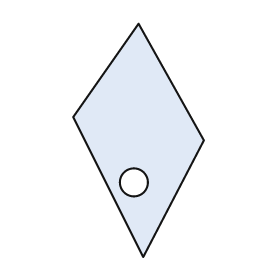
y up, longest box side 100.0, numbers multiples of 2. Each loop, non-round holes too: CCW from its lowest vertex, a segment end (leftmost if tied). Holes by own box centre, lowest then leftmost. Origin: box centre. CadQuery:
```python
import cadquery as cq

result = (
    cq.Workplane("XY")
    .moveTo(2.0, -50.0)
    .lineTo(28.0, 0.0)
    .lineTo(0.0, 50.0)
    .lineTo(-28.0, 10.0)
    .close()
    .moveTo(-2.0, -18.0)
    .circle(6.0)
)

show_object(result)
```